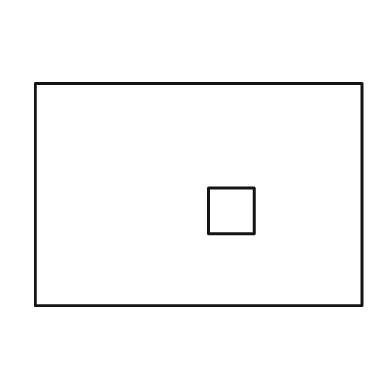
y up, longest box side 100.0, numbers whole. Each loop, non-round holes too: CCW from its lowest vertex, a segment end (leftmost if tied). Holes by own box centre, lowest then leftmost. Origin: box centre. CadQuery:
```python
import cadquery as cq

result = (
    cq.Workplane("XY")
    .moveTo(-50.0, -34.0)
    .lineTo(50.0, -34.0)
    .lineTo(50.0, 34.0)
    .lineTo(-50.0, 34.0)
    .close()
    .moveTo(3.0, -12.0)
    .lineTo(17.0, -12.0)
    .lineTo(17.0, 2.0)
    .lineTo(3.0, 2.0)
    .close()
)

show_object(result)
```